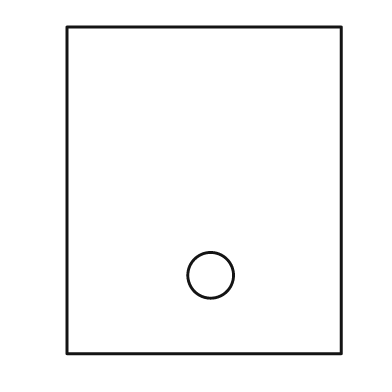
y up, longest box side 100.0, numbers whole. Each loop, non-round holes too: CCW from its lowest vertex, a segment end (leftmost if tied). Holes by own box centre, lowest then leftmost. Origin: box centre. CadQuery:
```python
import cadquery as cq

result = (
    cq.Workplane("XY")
    .moveTo(-42.0, -50.0)
    .lineTo(42.0, -50.0)
    .lineTo(42.0, 50.0)
    .lineTo(-42.0, 50.0)
    .close()
    .moveTo(2.0, -26.0)
    .circle(7.0)
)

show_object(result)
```